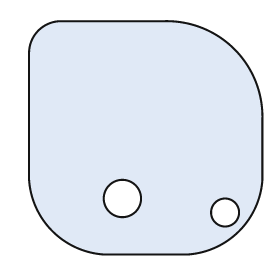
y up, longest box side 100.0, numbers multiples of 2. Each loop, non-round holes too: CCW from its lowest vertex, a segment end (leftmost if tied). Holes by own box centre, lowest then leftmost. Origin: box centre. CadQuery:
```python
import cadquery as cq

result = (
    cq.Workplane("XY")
    .moveTo(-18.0, -50.0)
    .lineTo(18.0, -50.0)
    .threePointArc((40.0, -40.0), (50.0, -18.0))
    .lineTo(50.0, 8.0)
    .threePointArc((38.0, 38.0), (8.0, 50.0))
    .lineTo(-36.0, 50.0)
    .threePointArc((-46.0, 46.0), (-50.0, 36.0))
    .lineTo(-50.0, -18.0)
    .threePointArc((-40.0, -40.0), (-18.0, -50.0))
    .close()
    .moveTo(34.0, -32.0)
    .circle(6.0)
    .moveTo(-10.0, -26.0)
    .circle(8.0)
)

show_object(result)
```